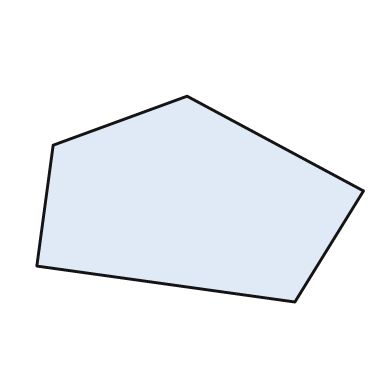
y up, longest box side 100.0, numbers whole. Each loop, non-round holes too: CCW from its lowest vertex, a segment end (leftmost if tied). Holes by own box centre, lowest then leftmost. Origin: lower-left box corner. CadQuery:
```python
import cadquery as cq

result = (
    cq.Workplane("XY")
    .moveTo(79.0, 0.0)
    .lineTo(100.0, 34.0)
    .lineTo(46.0, 63.0)
    .lineTo(5.0, 48.0)
    .lineTo(0.0, 11.0)
    .close()
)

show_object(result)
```